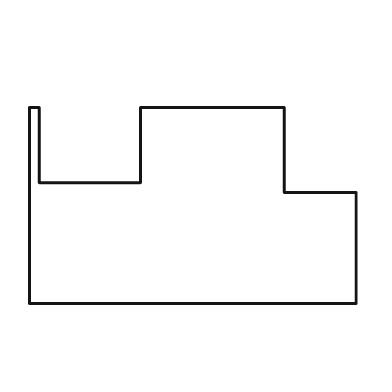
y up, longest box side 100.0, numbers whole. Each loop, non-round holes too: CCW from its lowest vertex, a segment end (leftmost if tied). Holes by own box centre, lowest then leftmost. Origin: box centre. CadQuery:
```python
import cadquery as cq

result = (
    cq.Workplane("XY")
    .moveTo(-50.0, -30.0)
    .lineTo(50.0, -30.0)
    .lineTo(50.0, 4.0)
    .lineTo(28.0, 4.0)
    .lineTo(28.0, 30.0)
    .lineTo(-16.0, 30.0)
    .lineTo(-16.0, 7.0)
    .lineTo(-47.0, 7.0)
    .lineTo(-47.0, 30.0)
    .lineTo(-50.0, 30.0)
    .close()
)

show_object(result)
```